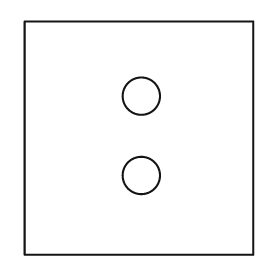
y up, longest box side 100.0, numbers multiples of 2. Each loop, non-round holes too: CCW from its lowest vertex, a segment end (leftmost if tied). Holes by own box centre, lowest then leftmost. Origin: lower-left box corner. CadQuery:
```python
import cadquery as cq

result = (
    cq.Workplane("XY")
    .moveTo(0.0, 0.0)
    .lineTo(98.0, 0.0)
    .lineTo(98.0, 100.0)
    .lineTo(0.0, 100.0)
    .close()
    .moveTo(50.0, 34.0)
    .circle(8.0)
    .moveTo(50.0, 68.0)
    .circle(8.0)
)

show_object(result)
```